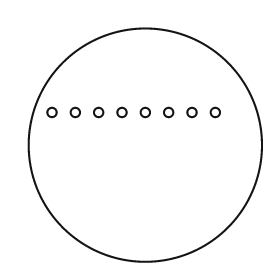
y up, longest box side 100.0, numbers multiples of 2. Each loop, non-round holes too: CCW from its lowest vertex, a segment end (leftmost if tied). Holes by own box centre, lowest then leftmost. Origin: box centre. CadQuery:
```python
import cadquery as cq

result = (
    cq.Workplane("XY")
    .moveTo(0.0, 0.0)
    .circle(50.0)
    .moveTo(-40.0, 14.0)
    .circle(2.0)
    .moveTo(-30.0, 14.0)
    .circle(2.0)
    .moveTo(-20.0, 14.0)
    .circle(2.0)
    .moveTo(-10.0, 14.0)
    .circle(2.0)
    .moveTo(0.0, 14.0)
    .circle(2.0)
    .moveTo(10.0, 14.0)
    .circle(2.0)
    .moveTo(20.0, 14.0)
    .circle(2.0)
    .moveTo(30.0, 14.0)
    .circle(2.0)
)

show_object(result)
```